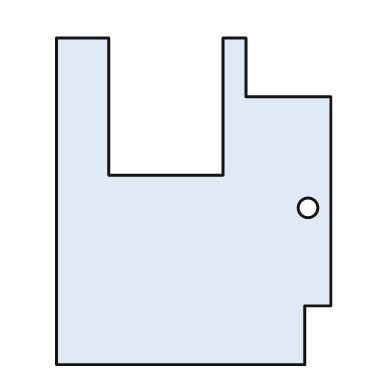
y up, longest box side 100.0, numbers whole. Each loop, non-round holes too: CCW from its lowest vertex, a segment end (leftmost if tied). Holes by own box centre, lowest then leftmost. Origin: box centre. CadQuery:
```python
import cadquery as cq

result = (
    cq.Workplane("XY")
    .moveTo(-42.0, -50.0)
    .lineTo(34.0, -50.0)
    .lineTo(34.0, -32.0)
    .lineTo(42.0, -32.0)
    .lineTo(42.0, 32.0)
    .lineTo(16.0, 32.0)
    .lineTo(16.0, 50.0)
    .lineTo(9.0, 50.0)
    .lineTo(9.0, 8.0)
    .lineTo(-26.0, 8.0)
    .lineTo(-26.0, 50.0)
    .lineTo(-42.0, 50.0)
    .close()
    .moveTo(35.0, -2.0)
    .circle(3.0)
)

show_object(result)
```